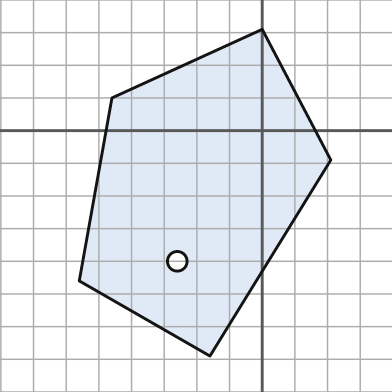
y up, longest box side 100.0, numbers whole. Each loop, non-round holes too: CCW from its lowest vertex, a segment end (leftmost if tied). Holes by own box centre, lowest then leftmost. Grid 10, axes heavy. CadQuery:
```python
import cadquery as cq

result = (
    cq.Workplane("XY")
    .moveTo(-16.0, -69.0)
    .lineTo(21.0, -9.0)
    .lineTo(0.0, 31.0)
    .lineTo(-46.0, 10.0)
    .lineTo(-56.0, -46.0)
    .close()
    .moveTo(-26.0, -40.0)
    .circle(3.0)
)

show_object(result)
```